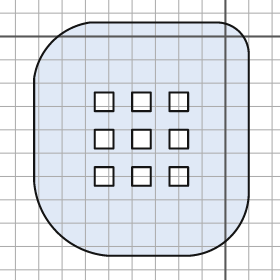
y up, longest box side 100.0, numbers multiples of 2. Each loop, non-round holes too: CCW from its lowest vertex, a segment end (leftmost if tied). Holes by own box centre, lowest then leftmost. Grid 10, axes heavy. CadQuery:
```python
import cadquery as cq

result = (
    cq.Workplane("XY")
    .moveTo(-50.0, -94.0)
    .lineTo(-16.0, -94.0)
    .threePointArc((2.0, -86.0), (10.0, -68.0))
    .lineTo(10.0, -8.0)
    .threePointArc((6.0, 2.0), (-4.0, 6.0))
    .lineTo(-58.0, 6.0)
    .threePointArc((-74.0, -2.0), (-82.0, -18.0))
    .lineTo(-82.0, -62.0)
    .threePointArc((-72.0, -84.0), (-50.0, -94.0))
    .close()
    .moveTo(-56.0, -64.0)
    .lineTo(-48.0, -64.0)
    .lineTo(-48.0, -56.0)
    .lineTo(-56.0, -56.0)
    .close()
    .moveTo(-40.0, -64.0)
    .lineTo(-32.0, -64.0)
    .lineTo(-32.0, -56.0)
    .lineTo(-40.0, -56.0)
    .close()
    .moveTo(-24.0, -64.0)
    .lineTo(-16.0, -64.0)
    .lineTo(-16.0, -56.0)
    .lineTo(-24.0, -56.0)
    .close()
    .moveTo(-56.0, -48.0)
    .lineTo(-48.0, -48.0)
    .lineTo(-48.0, -40.0)
    .lineTo(-56.0, -40.0)
    .close()
    .moveTo(-40.0, -48.0)
    .lineTo(-32.0, -48.0)
    .lineTo(-32.0, -40.0)
    .lineTo(-40.0, -40.0)
    .close()
    .moveTo(-24.0, -48.0)
    .lineTo(-16.0, -48.0)
    .lineTo(-16.0, -40.0)
    .lineTo(-24.0, -40.0)
    .close()
    .moveTo(-56.0, -32.0)
    .lineTo(-48.0, -32.0)
    .lineTo(-48.0, -24.0)
    .lineTo(-56.0, -24.0)
    .close()
    .moveTo(-40.0, -32.0)
    .lineTo(-32.0, -32.0)
    .lineTo(-32.0, -24.0)
    .lineTo(-40.0, -24.0)
    .close()
    .moveTo(-24.0, -32.0)
    .lineTo(-16.0, -32.0)
    .lineTo(-16.0, -24.0)
    .lineTo(-24.0, -24.0)
    .close()
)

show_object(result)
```